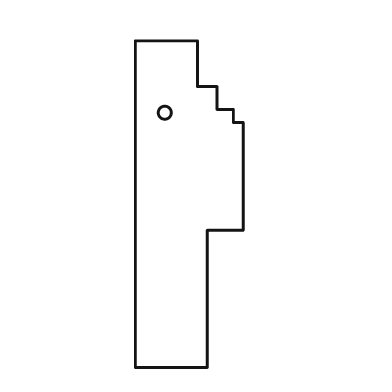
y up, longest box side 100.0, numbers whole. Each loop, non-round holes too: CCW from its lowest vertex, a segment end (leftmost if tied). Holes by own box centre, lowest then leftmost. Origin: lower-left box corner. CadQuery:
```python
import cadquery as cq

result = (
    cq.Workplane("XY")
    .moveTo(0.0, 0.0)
    .lineTo(22.0, 0.0)
    .lineTo(22.0, 42.0)
    .lineTo(33.0, 42.0)
    .lineTo(33.0, 75.0)
    .lineTo(30.0, 75.0)
    .lineTo(30.0, 79.0)
    .lineTo(25.0, 79.0)
    .lineTo(25.0, 86.0)
    .lineTo(19.0, 86.0)
    .lineTo(19.0, 100.0)
    .lineTo(0.0, 100.0)
    .close()
    .moveTo(9.0, 78.0)
    .circle(2.0)
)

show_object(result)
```